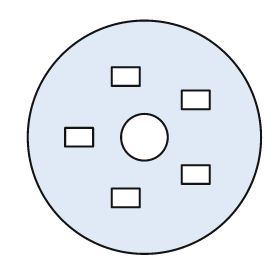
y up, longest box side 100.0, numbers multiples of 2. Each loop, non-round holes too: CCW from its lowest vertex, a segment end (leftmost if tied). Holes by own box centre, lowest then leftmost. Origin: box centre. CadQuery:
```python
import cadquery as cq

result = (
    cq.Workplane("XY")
    .moveTo(0.0, 0.0)
    .circle(50.0)
    .moveTo(-14.0, -30.0)
    .lineTo(-2.0, -30.0)
    .lineTo(-2.0, -22.0)
    .lineTo(-14.0, -22.0)
    .close()
    .moveTo(16.0, -20.0)
    .lineTo(28.0, -20.0)
    .lineTo(28.0, -12.0)
    .lineTo(16.0, -12.0)
    .close()
    .moveTo(-34.0, -4.0)
    .lineTo(-22.0, -4.0)
    .lineTo(-22.0, 4.0)
    .lineTo(-34.0, 4.0)
    .close()
    .moveTo(0.0, 0.0)
    .circle(10.0)
    .moveTo(16.0, 12.0)
    .lineTo(28.0, 12.0)
    .lineTo(28.0, 20.0)
    .lineTo(16.0, 20.0)
    .close()
    .moveTo(-14.0, 22.0)
    .lineTo(-2.0, 22.0)
    .lineTo(-2.0, 30.0)
    .lineTo(-14.0, 30.0)
    .close()
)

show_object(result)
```